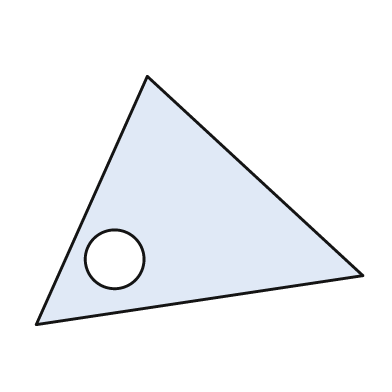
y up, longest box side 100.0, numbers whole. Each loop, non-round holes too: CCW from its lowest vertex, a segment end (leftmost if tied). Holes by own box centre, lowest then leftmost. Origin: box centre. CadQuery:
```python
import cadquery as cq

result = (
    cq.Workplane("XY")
    .moveTo(-50.0, -38.0)
    .lineTo(50.0, -23.0)
    .lineTo(-16.0, 38.0)
    .close()
    .moveTo(-26.0, -18.0)
    .circle(9.0)
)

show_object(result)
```